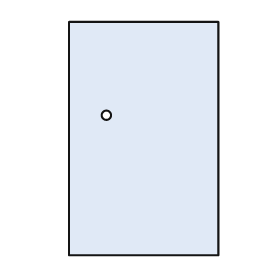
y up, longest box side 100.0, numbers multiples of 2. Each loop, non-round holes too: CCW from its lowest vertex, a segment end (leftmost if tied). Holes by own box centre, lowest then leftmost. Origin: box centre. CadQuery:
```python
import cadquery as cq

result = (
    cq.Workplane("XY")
    .moveTo(-32.0, -50.0)
    .lineTo(32.0, -50.0)
    .lineTo(32.0, 50.0)
    .lineTo(-32.0, 50.0)
    .close()
    .moveTo(-16.0, 10.0)
    .circle(2.0)
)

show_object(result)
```